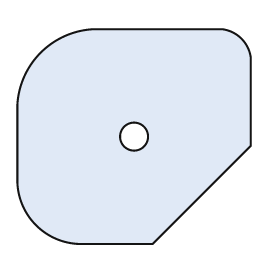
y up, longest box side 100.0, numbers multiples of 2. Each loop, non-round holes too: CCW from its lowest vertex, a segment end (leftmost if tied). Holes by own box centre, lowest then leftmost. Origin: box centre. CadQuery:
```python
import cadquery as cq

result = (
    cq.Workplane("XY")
    .moveTo(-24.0, -46.0)
    .lineTo(8.0, -46.0)
    .lineTo(50.0, -4.0)
    .lineTo(50.0, 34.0)
    .threePointArc((46.0, 42.0), (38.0, 46.0))
    .lineTo(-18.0, 46.0)
    .threePointArc((-40.0, 36.0), (-50.0, 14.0))
    .lineTo(-50.0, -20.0)
    .threePointArc((-42.0, -38.0), (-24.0, -46.0))
    .close()
    .moveTo(0.0, 0.0)
    .circle(6.0)
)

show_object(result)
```